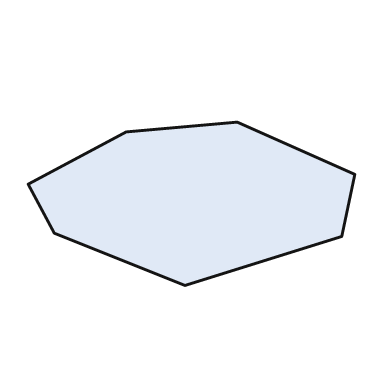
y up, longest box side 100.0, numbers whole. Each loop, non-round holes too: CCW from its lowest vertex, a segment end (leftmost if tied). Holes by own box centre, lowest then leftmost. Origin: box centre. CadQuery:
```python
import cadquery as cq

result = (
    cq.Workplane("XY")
    .moveTo(-2.0, -25.0)
    .lineTo(46.0, -10.0)
    .lineTo(50.0, 9.0)
    .lineTo(14.0, 25.0)
    .lineTo(-20.0, 22.0)
    .lineTo(-50.0, 6.0)
    .lineTo(-42.0, -9.0)
    .close()
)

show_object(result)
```